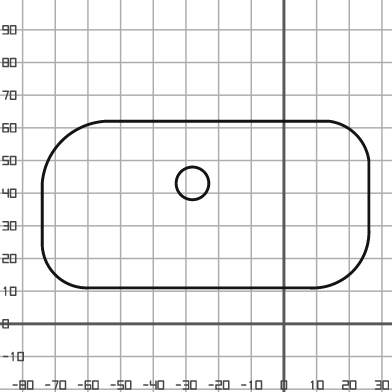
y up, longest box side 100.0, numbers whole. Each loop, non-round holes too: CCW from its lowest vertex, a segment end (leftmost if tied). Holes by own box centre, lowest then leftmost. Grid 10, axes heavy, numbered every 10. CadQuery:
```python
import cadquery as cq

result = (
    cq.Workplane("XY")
    .moveTo(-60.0, 11.0)
    .lineTo(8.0, 11.0)
    .threePointArc((21.0, 16.0), (26.0, 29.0))
    .lineTo(26.0, 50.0)
    .threePointArc((22.0, 58.0), (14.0, 62.0))
    .lineTo(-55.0, 62.0)
    .threePointArc((-68.0, 56.0), (-74.0, 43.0))
    .lineTo(-74.0, 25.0)
    .threePointArc((-70.0, 15.0), (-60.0, 11.0))
    .close()
    .moveTo(-28.0, 43.0)
    .circle(5.0)
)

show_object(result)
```